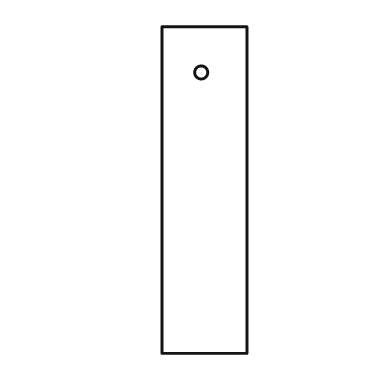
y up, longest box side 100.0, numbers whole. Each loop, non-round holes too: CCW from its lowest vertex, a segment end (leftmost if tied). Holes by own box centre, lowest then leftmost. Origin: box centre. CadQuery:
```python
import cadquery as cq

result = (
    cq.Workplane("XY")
    .moveTo(-13.0, -50.0)
    .lineTo(13.0, -50.0)
    .lineTo(13.0, 50.0)
    .lineTo(-13.0, 50.0)
    .close()
    .moveTo(-1.0, 36.0)
    .circle(2.0)
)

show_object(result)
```